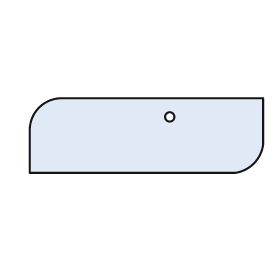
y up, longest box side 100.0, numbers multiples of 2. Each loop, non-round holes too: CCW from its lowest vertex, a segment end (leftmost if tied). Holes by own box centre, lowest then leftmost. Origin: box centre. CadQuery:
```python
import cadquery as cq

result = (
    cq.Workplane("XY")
    .moveTo(-50.0, -16.0)
    .lineTo(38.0, -16.0)
    .threePointArc((46.0, -12.0), (50.0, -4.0))
    .lineTo(50.0, 16.0)
    .lineTo(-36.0, 16.0)
    .threePointArc((-46.0, 12.0), (-50.0, 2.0))
    .close()
    .moveTo(10.0, 8.0)
    .circle(2.0)
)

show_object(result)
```